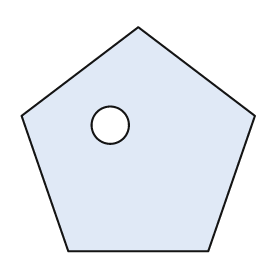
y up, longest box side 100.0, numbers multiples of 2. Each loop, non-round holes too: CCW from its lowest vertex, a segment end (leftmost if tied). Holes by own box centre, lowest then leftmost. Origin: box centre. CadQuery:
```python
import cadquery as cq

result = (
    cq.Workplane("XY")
    .moveTo(-30.0, -48.0)
    .lineTo(30.0, -48.0)
    .lineTo(50.0, 10.0)
    .lineTo(0.0, 48.0)
    .lineTo(-50.0, 10.0)
    .close()
    .moveTo(-12.0, 6.0)
    .circle(8.0)
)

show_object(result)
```